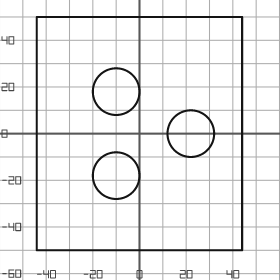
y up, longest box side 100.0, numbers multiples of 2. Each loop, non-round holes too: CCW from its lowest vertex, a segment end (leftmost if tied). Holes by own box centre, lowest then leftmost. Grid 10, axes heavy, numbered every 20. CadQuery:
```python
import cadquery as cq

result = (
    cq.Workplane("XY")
    .moveTo(-44.0, -50.0)
    .lineTo(44.0, -50.0)
    .lineTo(44.0, 50.0)
    .lineTo(-44.0, 50.0)
    .close()
    .moveTo(-10.0, -18.0)
    .circle(10.0)
    .moveTo(22.0, 0.0)
    .circle(10.0)
    .moveTo(-10.0, 18.0)
    .circle(10.0)
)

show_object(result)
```